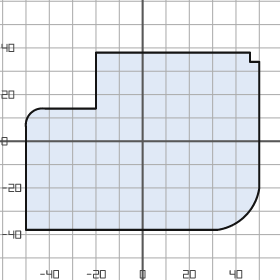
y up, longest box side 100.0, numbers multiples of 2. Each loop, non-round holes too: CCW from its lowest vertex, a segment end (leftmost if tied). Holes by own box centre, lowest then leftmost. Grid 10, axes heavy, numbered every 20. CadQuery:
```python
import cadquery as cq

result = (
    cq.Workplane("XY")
    .moveTo(-50.0, -38.0)
    .lineTo(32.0, -38.0)
    .threePointArc((44.0, -32.0), (50.0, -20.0))
    .lineTo(50.0, 34.0)
    .lineTo(46.0, 34.0)
    .lineTo(46.0, 38.0)
    .lineTo(-20.0, 38.0)
    .lineTo(-20.0, 14.0)
    .lineTo(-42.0, 14.0)
    .threePointArc((-48.0, 12.0), (-50.0, 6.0))
    .close()
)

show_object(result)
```